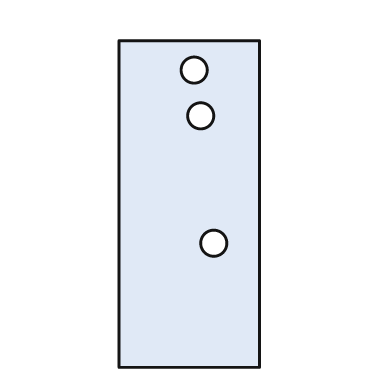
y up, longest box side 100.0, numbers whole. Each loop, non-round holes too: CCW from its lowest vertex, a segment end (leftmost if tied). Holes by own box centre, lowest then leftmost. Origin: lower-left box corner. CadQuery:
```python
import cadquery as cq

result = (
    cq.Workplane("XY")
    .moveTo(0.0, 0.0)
    .lineTo(43.0, 0.0)
    .lineTo(43.0, 100.0)
    .lineTo(0.0, 100.0)
    .close()
    .moveTo(29.0, 38.0)
    .circle(4.0)
    .moveTo(25.0, 77.0)
    .circle(4.0)
    .moveTo(23.0, 91.0)
    .circle(4.0)
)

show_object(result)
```